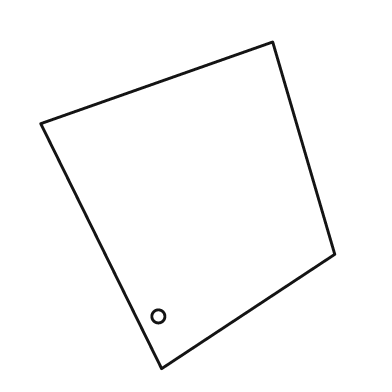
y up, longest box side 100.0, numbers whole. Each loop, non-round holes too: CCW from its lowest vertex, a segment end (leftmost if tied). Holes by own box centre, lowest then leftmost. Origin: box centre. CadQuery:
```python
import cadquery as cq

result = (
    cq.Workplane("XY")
    .moveTo(-8.0, -50.0)
    .lineTo(45.0, -15.0)
    .lineTo(26.0, 50.0)
    .lineTo(-45.0, 25.0)
    .close()
    .moveTo(-9.0, -34.0)
    .circle(2.0)
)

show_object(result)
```